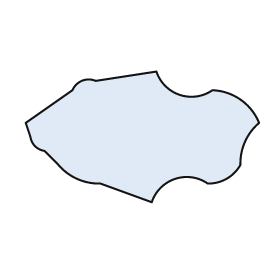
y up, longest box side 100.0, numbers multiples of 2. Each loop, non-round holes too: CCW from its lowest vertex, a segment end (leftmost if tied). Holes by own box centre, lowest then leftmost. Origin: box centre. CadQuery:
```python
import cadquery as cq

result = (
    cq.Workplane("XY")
    .moveTo(4.0, -28.0)
    .threePointArc((14.0, -18.0), (28.0, -20.0))
    .threePointArc((36.0, -18.0), (42.0, -12.0))
    .threePointArc((44.0, -2.0), (50.0, 6.0))
    .threePointArc((42.0, 16.0), (30.0, 20.0))
    .threePointArc((16.0, 18.0), (6.0, 28.0))
    .lineTo(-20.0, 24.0)
    .threePointArc((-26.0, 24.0), (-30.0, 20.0))
    .lineTo(-50.0, 6.0)
    .lineTo(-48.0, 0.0)
    .threePointArc((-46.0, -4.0), (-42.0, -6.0))
    .lineTo(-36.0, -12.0)
    .threePointArc((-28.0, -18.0), (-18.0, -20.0))
    .close()
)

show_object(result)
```